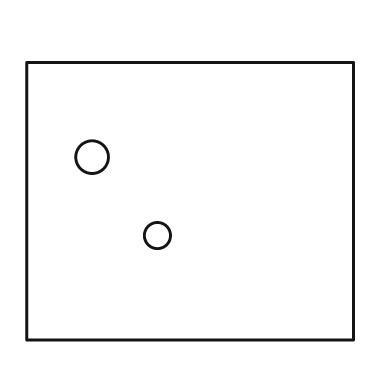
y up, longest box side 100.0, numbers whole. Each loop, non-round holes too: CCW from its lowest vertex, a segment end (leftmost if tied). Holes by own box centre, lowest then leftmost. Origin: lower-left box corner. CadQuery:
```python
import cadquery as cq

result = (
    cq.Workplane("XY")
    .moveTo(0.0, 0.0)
    .lineTo(100.0, 0.0)
    .lineTo(100.0, 85.0)
    .lineTo(0.0, 85.0)
    .close()
    .moveTo(40.0, 32.0)
    .circle(4.0)
    .moveTo(20.0, 56.0)
    .circle(5.0)
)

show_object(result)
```